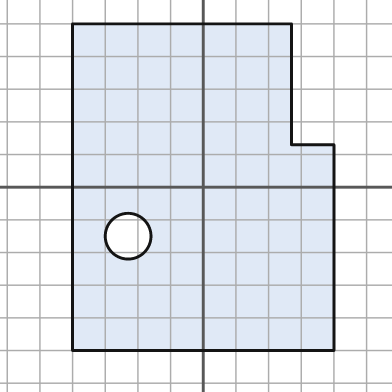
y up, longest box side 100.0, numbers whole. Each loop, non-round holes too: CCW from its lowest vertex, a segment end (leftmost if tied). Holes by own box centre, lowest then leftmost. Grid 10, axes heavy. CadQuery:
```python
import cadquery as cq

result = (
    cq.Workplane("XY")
    .moveTo(-40.0, -50.0)
    .lineTo(40.0, -50.0)
    .lineTo(40.0, 13.0)
    .lineTo(27.0, 13.0)
    .lineTo(27.0, 50.0)
    .lineTo(-40.0, 50.0)
    .close()
    .moveTo(-23.0, -15.0)
    .circle(7.0)
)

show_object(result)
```